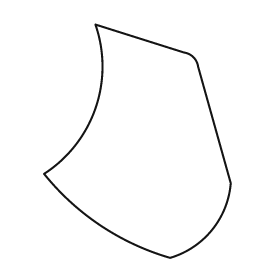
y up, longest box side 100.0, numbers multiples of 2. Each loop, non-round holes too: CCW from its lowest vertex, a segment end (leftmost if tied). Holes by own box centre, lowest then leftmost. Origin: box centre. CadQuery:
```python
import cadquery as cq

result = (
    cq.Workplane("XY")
    .moveTo(14.0, -50.0)
    .threePointArc((32.0, -38.0), (40.0, -18.0))
    .lineTo(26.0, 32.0)
    .threePointArc((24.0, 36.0), (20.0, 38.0))
    .lineTo(-18.0, 50.0)
    .threePointArc((-18.0, 14.0), (-40.0, -14.0))
    .threePointArc((-16.0, -36.0), (14.0, -50.0))
    .close()
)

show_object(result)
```